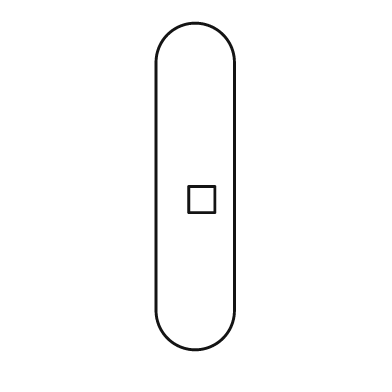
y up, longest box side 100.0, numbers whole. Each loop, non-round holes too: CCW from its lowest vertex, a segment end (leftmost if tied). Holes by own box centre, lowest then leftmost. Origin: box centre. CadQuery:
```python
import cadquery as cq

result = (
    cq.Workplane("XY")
    .moveTo(-12.0, -38.0)
    .threePointArc((0.0, -50.0), (12.0, -38.0))
    .lineTo(12.0, 38.0)
    .threePointArc((0.0, 50.0), (-12.0, 38.0))
    .close()
    .moveTo(-2.0, -8.0)
    .lineTo(6.0, -8.0)
    .lineTo(6.0, 0.0)
    .lineTo(-2.0, 0.0)
    .close()
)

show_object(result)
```